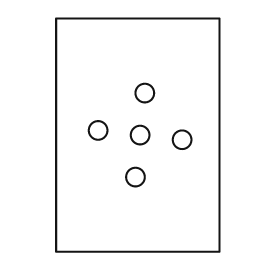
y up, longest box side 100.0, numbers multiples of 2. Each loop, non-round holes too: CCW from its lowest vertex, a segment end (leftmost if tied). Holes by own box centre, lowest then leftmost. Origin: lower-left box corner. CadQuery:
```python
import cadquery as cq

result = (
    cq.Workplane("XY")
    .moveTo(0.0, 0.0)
    .lineTo(70.0, 0.0)
    .lineTo(70.0, 100.0)
    .lineTo(0.0, 100.0)
    .close()
    .moveTo(34.0, 32.0)
    .circle(4.0)
    .moveTo(54.0, 48.0)
    .circle(4.0)
    .moveTo(36.0, 50.0)
    .circle(4.0)
    .moveTo(18.0, 52.0)
    .circle(4.0)
    .moveTo(38.0, 68.0)
    .circle(4.0)
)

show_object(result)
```